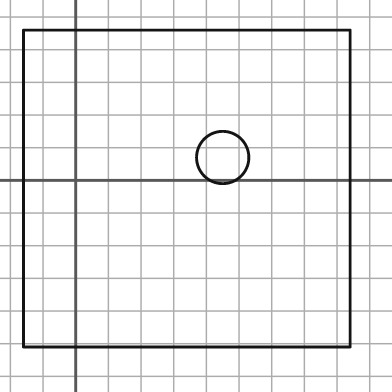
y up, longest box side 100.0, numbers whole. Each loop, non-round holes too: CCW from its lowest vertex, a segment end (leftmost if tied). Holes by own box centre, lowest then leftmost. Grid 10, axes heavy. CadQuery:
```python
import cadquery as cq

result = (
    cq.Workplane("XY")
    .moveTo(-16.0, -51.0)
    .lineTo(84.0, -51.0)
    .lineTo(84.0, 46.0)
    .lineTo(-16.0, 46.0)
    .close()
    .moveTo(45.0, 7.0)
    .circle(8.0)
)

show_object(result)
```